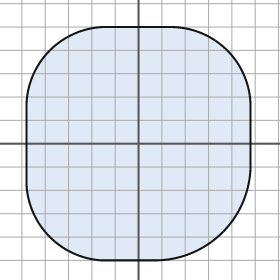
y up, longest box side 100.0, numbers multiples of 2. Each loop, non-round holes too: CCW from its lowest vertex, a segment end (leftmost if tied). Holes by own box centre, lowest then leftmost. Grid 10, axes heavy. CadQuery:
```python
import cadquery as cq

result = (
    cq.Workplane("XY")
    .moveTo(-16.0, -50.0)
    .lineTo(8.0, -50.0)
    .threePointArc((36.0, -38.0), (48.0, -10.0))
    .lineTo(48.0, 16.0)
    .threePointArc((38.0, 40.0), (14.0, 50.0))
    .lineTo(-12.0, 50.0)
    .threePointArc((-38.0, 40.0), (-48.0, 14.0))
    .lineTo(-48.0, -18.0)
    .threePointArc((-38.0, -40.0), (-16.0, -50.0))
    .close()
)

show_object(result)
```